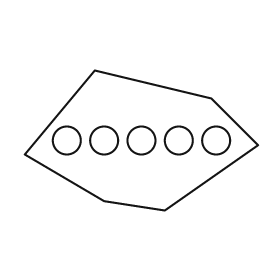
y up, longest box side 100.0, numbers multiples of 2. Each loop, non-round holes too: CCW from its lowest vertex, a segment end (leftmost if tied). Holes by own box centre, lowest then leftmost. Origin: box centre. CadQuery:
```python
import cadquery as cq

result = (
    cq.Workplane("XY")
    .moveTo(10.0, -30.0)
    .lineTo(50.0, -2.0)
    .lineTo(30.0, 18.0)
    .lineTo(-20.0, 30.0)
    .lineTo(-50.0, -6.0)
    .lineTo(-16.0, -26.0)
    .close()
    .moveTo(-32.0, 0.0)
    .circle(6.0)
    .moveTo(-16.0, 0.0)
    .circle(6.0)
    .moveTo(0.0, 0.0)
    .circle(6.0)
    .moveTo(16.0, 0.0)
    .circle(6.0)
    .moveTo(32.0, 0.0)
    .circle(6.0)
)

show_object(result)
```